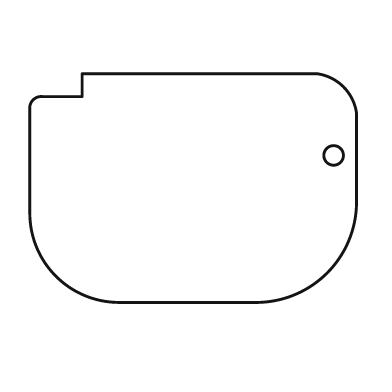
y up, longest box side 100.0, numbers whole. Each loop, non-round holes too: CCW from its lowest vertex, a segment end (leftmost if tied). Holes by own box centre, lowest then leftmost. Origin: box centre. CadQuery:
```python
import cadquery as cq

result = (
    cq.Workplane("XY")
    .moveTo(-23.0, -35.0)
    .lineTo(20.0, -35.0)
    .threePointArc((41.0, -26.0), (50.0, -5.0))
    .lineTo(50.0, 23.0)
    .threePointArc((46.0, 31.0), (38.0, 35.0))
    .lineTo(-34.0, 35.0)
    .lineTo(-34.0, 28.0)
    .lineTo(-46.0, 28.0)
    .threePointArc((-49.0, 27.0), (-50.0, 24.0))
    .lineTo(-50.0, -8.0)
    .threePointArc((-42.0, -27.0), (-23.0, -35.0))
    .close()
    .moveTo(43.0, 10.0)
    .circle(3.0)
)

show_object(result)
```